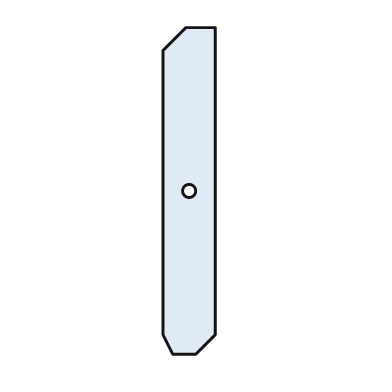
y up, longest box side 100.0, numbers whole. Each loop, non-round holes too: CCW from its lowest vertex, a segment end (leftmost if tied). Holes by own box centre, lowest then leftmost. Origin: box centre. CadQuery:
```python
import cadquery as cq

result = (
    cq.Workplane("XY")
    .moveTo(-5.0, -50.0)
    .lineTo(2.0, -50.0)
    .lineTo(8.0, -44.0)
    .lineTo(8.0, 50.0)
    .lineTo(-1.0, 50.0)
    .lineTo(-8.0, 43.0)
    .lineTo(-8.0, -44.0)
    .close()
    .moveTo(0.0, 0.0)
    .circle(2.0)
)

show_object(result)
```